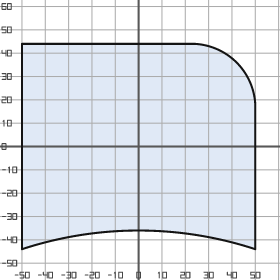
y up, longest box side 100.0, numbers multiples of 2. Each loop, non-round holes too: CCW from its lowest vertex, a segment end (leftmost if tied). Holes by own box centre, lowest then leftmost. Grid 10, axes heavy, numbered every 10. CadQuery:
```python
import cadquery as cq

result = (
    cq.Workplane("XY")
    .moveTo(-50.0, -44.0)
    .threePointArc((0.0, -36.0), (50.0, -44.0))
    .lineTo(50.0, 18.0)
    .threePointArc((42.0, 36.0), (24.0, 44.0))
    .lineTo(-50.0, 44.0)
    .close()
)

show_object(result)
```